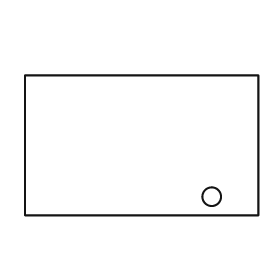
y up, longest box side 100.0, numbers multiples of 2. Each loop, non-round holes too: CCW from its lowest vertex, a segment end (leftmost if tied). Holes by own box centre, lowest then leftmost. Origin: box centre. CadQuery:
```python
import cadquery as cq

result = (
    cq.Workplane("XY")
    .moveTo(-50.0, -30.0)
    .lineTo(50.0, -30.0)
    .lineTo(50.0, 30.0)
    .lineTo(-50.0, 30.0)
    .close()
    .moveTo(30.0, -22.0)
    .circle(4.0)
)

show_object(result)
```